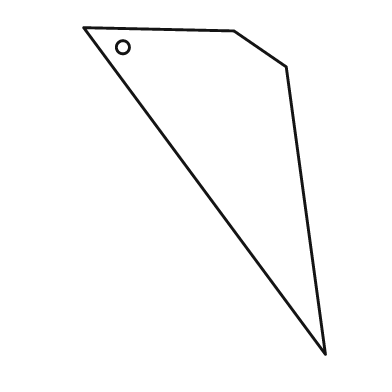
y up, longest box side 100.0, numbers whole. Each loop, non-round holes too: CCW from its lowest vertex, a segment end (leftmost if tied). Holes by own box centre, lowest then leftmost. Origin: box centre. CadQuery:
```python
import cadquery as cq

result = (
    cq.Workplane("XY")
    .moveTo(37.0, -50.0)
    .lineTo(25.0, 38.0)
    .lineTo(9.0, 49.0)
    .lineTo(-37.0, 50.0)
    .close()
    .moveTo(-25.0, 44.0)
    .circle(2.0)
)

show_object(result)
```